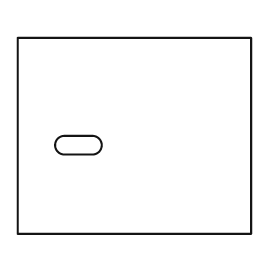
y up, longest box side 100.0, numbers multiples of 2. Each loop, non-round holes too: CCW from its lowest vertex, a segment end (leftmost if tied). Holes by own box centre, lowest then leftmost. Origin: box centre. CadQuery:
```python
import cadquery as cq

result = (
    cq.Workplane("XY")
    .moveTo(-50.0, -42.0)
    .lineTo(50.0, -42.0)
    .lineTo(50.0, 42.0)
    .lineTo(-50.0, 42.0)
    .close()
    .moveTo(-30.0, -8.0)
    .lineTo(-18.0, -8.0)
    .threePointArc((-14.0, -4.0), (-18.0, 0.0))
    .lineTo(-30.0, 0.0)
    .threePointArc((-34.0, -4.0), (-30.0, -8.0))
    .close()
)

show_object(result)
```